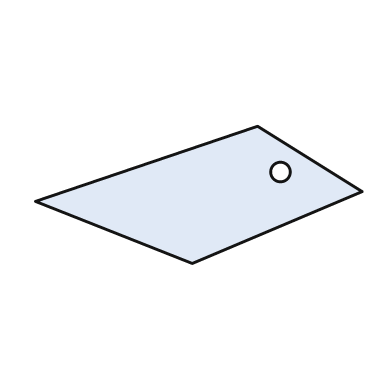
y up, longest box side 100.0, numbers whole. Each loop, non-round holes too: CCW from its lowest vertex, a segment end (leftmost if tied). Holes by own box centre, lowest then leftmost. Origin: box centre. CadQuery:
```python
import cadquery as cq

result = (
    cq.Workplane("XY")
    .moveTo(-2.0, -21.0)
    .lineTo(50.0, 1.0)
    .lineTo(18.0, 21.0)
    .lineTo(-50.0, -2.0)
    .close()
    .moveTo(25.0, 7.0)
    .circle(3.0)
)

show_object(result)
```